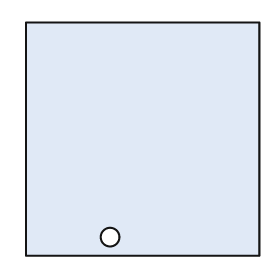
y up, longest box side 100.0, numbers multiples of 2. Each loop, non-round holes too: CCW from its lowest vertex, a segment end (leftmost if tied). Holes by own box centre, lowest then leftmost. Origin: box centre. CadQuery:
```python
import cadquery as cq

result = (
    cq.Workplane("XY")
    .moveTo(-50.0, -50.0)
    .lineTo(50.0, -50.0)
    .lineTo(50.0, 50.0)
    .lineTo(-50.0, 50.0)
    .close()
    .moveTo(-14.0, -42.0)
    .circle(4.0)
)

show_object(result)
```